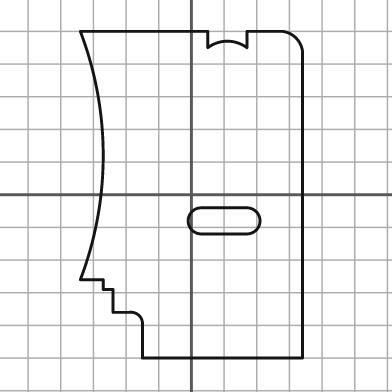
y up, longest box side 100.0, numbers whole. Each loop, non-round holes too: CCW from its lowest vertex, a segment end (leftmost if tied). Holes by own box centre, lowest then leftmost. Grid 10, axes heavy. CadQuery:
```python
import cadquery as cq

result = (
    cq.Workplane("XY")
    .moveTo(-15.0, -50.0)
    .lineTo(34.0, -50.0)
    .lineTo(34.0, 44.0)
    .threePointArc((32.0, 48.0), (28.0, 50.0))
    .lineTo(17.0, 50.0)
    .lineTo(17.0, 45.0)
    .threePointArc((11.0, 47.0), (5.0, 45.0))
    .lineTo(5.0, 50.0)
    .lineTo(-34.0, 50.0)
    .threePointArc((-27.0, 12.0), (-34.0, -26.0))
    .lineTo(-27.0, -26.0)
    .lineTo(-27.0, -29.0)
    .lineTo(-24.0, -29.0)
    .lineTo(-24.0, -36.0)
    .lineTo(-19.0, -36.0)
    .threePointArc((-16.0, -37.0), (-15.0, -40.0))
    .close()
    .moveTo(3.0, -12.0)
    .lineTo(17.0, -12.0)
    .threePointArc((21.0, -8.0), (17.0, -4.0))
    .lineTo(3.0, -4.0)
    .threePointArc((-1.0, -8.0), (3.0, -12.0))
    .close()
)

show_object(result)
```